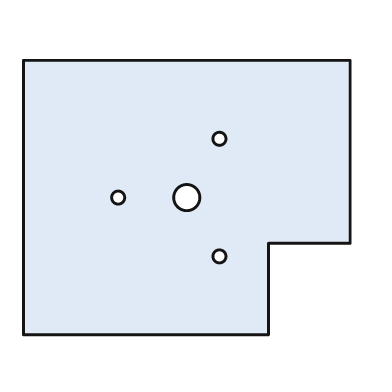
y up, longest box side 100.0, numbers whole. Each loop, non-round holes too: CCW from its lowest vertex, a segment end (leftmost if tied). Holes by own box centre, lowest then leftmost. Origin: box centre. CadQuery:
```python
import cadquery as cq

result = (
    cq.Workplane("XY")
    .moveTo(-50.0, -42.0)
    .lineTo(25.0, -42.0)
    .lineTo(25.0, -14.0)
    .lineTo(50.0, -14.0)
    .lineTo(50.0, 42.0)
    .lineTo(-50.0, 42.0)
    .close()
    .moveTo(10.0, -18.0)
    .circle(2.0)
    .moveTo(-21.0, 0.0)
    .circle(2.0)
    .moveTo(0.0, 0.0)
    .circle(4.0)
    .moveTo(10.0, 18.0)
    .circle(2.0)
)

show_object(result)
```